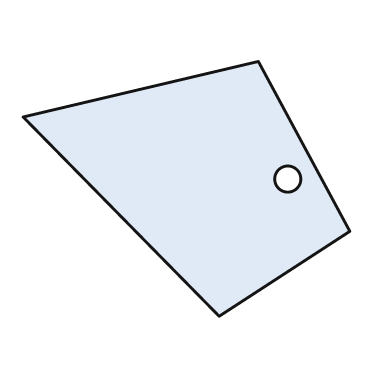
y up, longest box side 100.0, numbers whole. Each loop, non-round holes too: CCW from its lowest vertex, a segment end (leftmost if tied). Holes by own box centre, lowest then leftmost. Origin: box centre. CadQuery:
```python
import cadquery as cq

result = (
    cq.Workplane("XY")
    .moveTo(10.0, -39.0)
    .lineTo(50.0, -13.0)
    .lineTo(22.0, 39.0)
    .lineTo(-50.0, 22.0)
    .close()
    .moveTo(31.0, 3.0)
    .circle(4.0)
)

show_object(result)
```